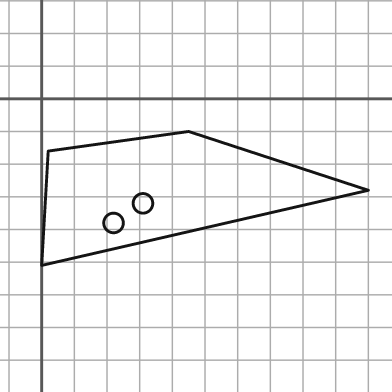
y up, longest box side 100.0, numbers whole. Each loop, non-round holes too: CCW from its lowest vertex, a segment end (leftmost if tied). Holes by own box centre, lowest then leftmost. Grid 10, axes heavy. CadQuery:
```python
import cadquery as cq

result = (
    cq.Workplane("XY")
    .moveTo(0.0, -51.0)
    .lineTo(100.0, -28.0)
    .lineTo(45.0, -10.0)
    .lineTo(2.0, -16.0)
    .close()
    .moveTo(22.0, -38.0)
    .circle(3.0)
    .moveTo(31.0, -32.0)
    .circle(3.0)
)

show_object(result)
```